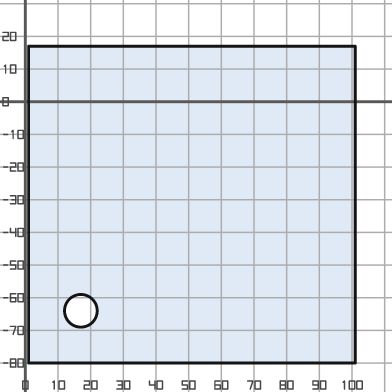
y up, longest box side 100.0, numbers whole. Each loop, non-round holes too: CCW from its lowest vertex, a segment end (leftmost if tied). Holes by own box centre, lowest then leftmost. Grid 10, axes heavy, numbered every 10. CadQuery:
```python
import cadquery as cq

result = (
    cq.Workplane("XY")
    .moveTo(1.0, -80.0)
    .lineTo(101.0, -80.0)
    .lineTo(101.0, 17.0)
    .lineTo(1.0, 17.0)
    .close()
    .moveTo(17.0, -64.0)
    .circle(5.0)
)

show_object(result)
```